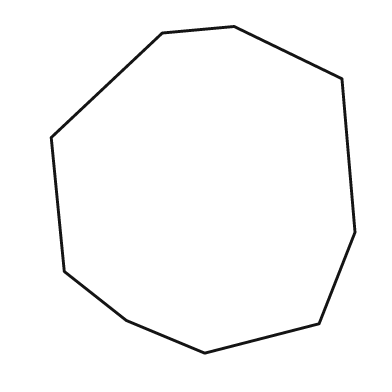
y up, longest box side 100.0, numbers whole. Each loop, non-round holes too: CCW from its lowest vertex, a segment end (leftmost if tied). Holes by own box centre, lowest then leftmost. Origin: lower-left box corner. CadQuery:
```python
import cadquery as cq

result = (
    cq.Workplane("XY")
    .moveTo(47.0, 0.0)
    .lineTo(82.0, 9.0)
    .lineTo(93.0, 37.0)
    .lineTo(89.0, 84.0)
    .lineTo(56.0, 100.0)
    .lineTo(34.0, 98.0)
    .lineTo(0.0, 66.0)
    .lineTo(4.0, 25.0)
    .lineTo(23.0, 10.0)
    .close()
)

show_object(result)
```